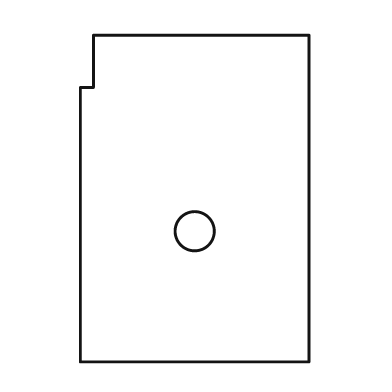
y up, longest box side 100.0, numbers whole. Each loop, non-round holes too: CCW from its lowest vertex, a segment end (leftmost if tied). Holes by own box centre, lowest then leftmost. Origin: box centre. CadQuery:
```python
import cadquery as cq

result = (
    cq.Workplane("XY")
    .moveTo(-35.0, -50.0)
    .lineTo(35.0, -50.0)
    .lineTo(35.0, 50.0)
    .lineTo(-31.0, 50.0)
    .lineTo(-31.0, 34.0)
    .lineTo(-35.0, 34.0)
    .close()
    .moveTo(0.0, -10.0)
    .circle(6.0)
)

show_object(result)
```